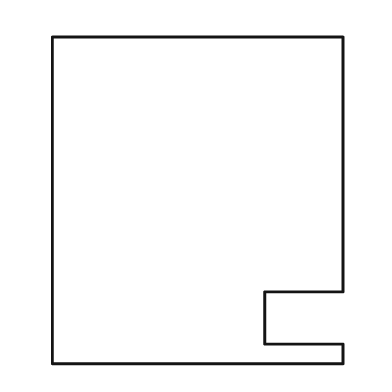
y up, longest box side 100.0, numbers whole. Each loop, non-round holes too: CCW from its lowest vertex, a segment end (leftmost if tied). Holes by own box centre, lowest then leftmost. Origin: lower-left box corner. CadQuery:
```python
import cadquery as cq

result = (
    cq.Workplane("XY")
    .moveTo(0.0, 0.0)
    .lineTo(89.0, 0.0)
    .lineTo(89.0, 6.0)
    .lineTo(65.0, 6.0)
    .lineTo(65.0, 22.0)
    .lineTo(89.0, 22.0)
    .lineTo(89.0, 100.0)
    .lineTo(0.0, 100.0)
    .close()
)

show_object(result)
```